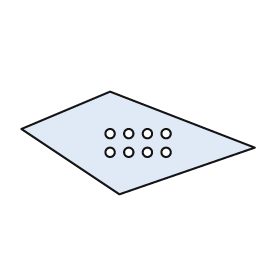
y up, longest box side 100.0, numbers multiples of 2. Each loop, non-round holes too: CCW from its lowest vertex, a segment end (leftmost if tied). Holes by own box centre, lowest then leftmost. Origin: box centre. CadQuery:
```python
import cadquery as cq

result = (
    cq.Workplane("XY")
    .moveTo(-8.0, -22.0)
    .lineTo(50.0, -2.0)
    .lineTo(-12.0, 22.0)
    .lineTo(-50.0, 6.0)
    .close()
    .moveTo(-12.0, -4.0)
    .circle(2.0)
    .moveTo(-4.0, -4.0)
    .circle(2.0)
    .moveTo(4.0, -4.0)
    .circle(2.0)
    .moveTo(12.0, -4.0)
    .circle(2.0)
    .moveTo(-12.0, 4.0)
    .circle(2.0)
    .moveTo(-4.0, 4.0)
    .circle(2.0)
    .moveTo(4.0, 4.0)
    .circle(2.0)
    .moveTo(12.0, 4.0)
    .circle(2.0)
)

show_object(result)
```